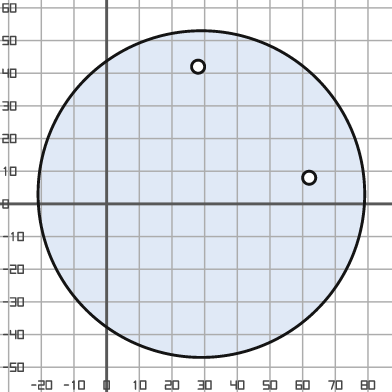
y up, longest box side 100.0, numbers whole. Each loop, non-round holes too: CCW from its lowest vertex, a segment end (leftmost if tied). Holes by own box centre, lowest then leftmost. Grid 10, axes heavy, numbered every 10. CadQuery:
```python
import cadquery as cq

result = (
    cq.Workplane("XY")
    .moveTo(29.0, 3.0)
    .circle(50.0)
    .moveTo(62.0, 8.0)
    .circle(2.0)
    .moveTo(28.0, 42.0)
    .circle(2.0)
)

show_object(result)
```